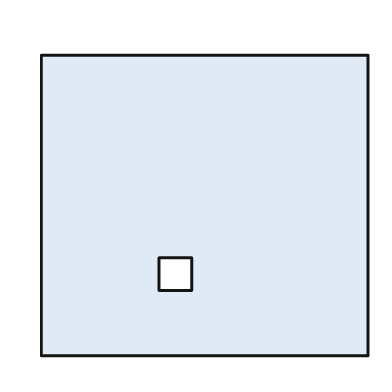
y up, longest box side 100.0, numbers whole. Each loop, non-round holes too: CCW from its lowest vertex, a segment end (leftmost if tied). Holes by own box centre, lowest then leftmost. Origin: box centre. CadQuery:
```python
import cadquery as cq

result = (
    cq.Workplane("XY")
    .moveTo(-50.0, -46.0)
    .lineTo(50.0, -46.0)
    .lineTo(50.0, 46.0)
    .lineTo(-50.0, 46.0)
    .close()
    .moveTo(-14.0, -26.0)
    .lineTo(-4.0, -26.0)
    .lineTo(-4.0, -16.0)
    .lineTo(-14.0, -16.0)
    .close()
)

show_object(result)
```